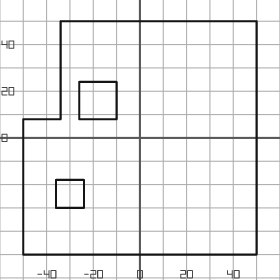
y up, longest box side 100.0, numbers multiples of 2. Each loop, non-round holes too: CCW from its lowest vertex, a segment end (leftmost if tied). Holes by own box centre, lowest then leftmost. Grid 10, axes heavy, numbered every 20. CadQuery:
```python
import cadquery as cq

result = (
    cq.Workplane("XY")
    .moveTo(-50.0, -50.0)
    .lineTo(50.0, -50.0)
    .lineTo(50.0, 50.0)
    .lineTo(-34.0, 50.0)
    .lineTo(-34.0, 8.0)
    .lineTo(-50.0, 8.0)
    .close()
    .moveTo(-36.0, -30.0)
    .lineTo(-24.0, -30.0)
    .lineTo(-24.0, -18.0)
    .lineTo(-36.0, -18.0)
    .close()
    .moveTo(-26.0, 8.0)
    .lineTo(-10.0, 8.0)
    .lineTo(-10.0, 24.0)
    .lineTo(-26.0, 24.0)
    .close()
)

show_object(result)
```